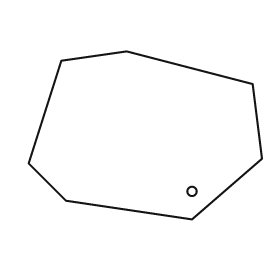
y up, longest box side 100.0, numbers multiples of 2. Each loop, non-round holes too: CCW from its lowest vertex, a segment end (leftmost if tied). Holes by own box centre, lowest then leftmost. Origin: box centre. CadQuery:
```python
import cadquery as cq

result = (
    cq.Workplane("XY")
    .moveTo(20.0, -36.0)
    .lineTo(50.0, -10.0)
    .lineTo(46.0, 22.0)
    .lineTo(-8.0, 36.0)
    .lineTo(-36.0, 32.0)
    .lineTo(-50.0, -12.0)
    .lineTo(-34.0, -28.0)
    .close()
    .moveTo(20.0, -24.0)
    .circle(2.0)
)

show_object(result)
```